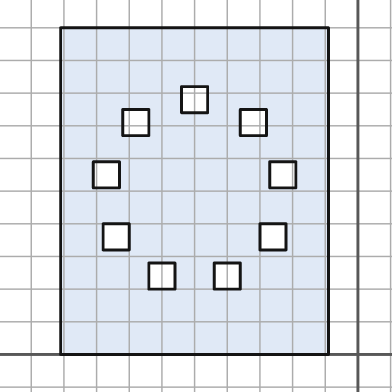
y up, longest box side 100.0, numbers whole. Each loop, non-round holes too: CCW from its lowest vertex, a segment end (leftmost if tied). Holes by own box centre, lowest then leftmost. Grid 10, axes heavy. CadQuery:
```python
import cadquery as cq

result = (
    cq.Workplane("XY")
    .moveTo(-91.0, 0.0)
    .lineTo(-9.0, 0.0)
    .lineTo(-9.0, 100.0)
    .lineTo(-91.0, 100.0)
    .close()
    .moveTo(-64.0, 20.0)
    .lineTo(-56.0, 20.0)
    .lineTo(-56.0, 28.0)
    .lineTo(-64.0, 28.0)
    .close()
    .moveTo(-44.0, 20.0)
    .lineTo(-36.0, 20.0)
    .lineTo(-36.0, 28.0)
    .lineTo(-44.0, 28.0)
    .close()
    .moveTo(-78.0, 32.0)
    .lineTo(-70.0, 32.0)
    .lineTo(-70.0, 40.0)
    .lineTo(-78.0, 40.0)
    .close()
    .moveTo(-30.0, 32.0)
    .lineTo(-22.0, 32.0)
    .lineTo(-22.0, 40.0)
    .lineTo(-30.0, 40.0)
    .close()
    .moveTo(-81.0, 51.0)
    .lineTo(-73.0, 51.0)
    .lineTo(-73.0, 59.0)
    .lineTo(-81.0, 59.0)
    .close()
    .moveTo(-27.0, 51.0)
    .lineTo(-19.0, 51.0)
    .lineTo(-19.0, 59.0)
    .lineTo(-27.0, 59.0)
    .close()
    .moveTo(-72.0, 67.0)
    .lineTo(-64.0, 67.0)
    .lineTo(-64.0, 75.0)
    .lineTo(-72.0, 75.0)
    .close()
    .moveTo(-36.0, 67.0)
    .lineTo(-28.0, 67.0)
    .lineTo(-28.0, 75.0)
    .lineTo(-36.0, 75.0)
    .close()
    .moveTo(-54.0, 74.0)
    .lineTo(-46.0, 74.0)
    .lineTo(-46.0, 82.0)
    .lineTo(-54.0, 82.0)
    .close()
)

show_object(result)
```